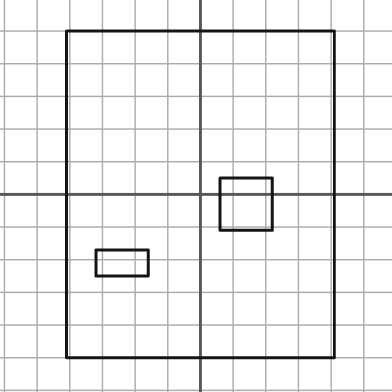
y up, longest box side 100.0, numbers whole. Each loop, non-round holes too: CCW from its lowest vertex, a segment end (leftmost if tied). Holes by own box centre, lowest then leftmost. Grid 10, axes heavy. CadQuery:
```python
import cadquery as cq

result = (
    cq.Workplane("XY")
    .moveTo(-41.0, -50.0)
    .lineTo(41.0, -50.0)
    .lineTo(41.0, 50.0)
    .lineTo(-41.0, 50.0)
    .close()
    .moveTo(-32.0, -25.0)
    .lineTo(-16.0, -25.0)
    .lineTo(-16.0, -17.0)
    .lineTo(-32.0, -17.0)
    .close()
    .moveTo(6.0, -11.0)
    .lineTo(22.0, -11.0)
    .lineTo(22.0, 5.0)
    .lineTo(6.0, 5.0)
    .close()
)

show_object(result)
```